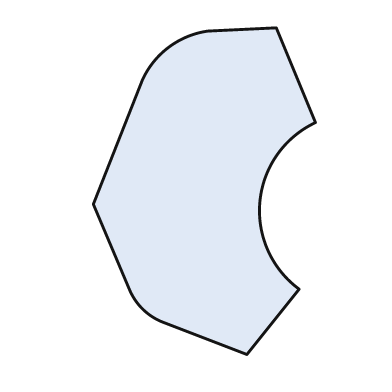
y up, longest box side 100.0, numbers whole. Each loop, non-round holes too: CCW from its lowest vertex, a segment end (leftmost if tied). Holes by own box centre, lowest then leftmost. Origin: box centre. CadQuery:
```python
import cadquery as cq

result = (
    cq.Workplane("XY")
    .moveTo(13.0, -50.0)
    .lineTo(29.0, -30.0)
    .threePointArc((17.0, -3.0), (34.0, 21.0))
    .lineTo(22.0, 50.0)
    .lineTo(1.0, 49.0)
    .threePointArc((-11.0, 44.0), (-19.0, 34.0))
    .lineTo(-34.0, -4.0)
    .lineTo(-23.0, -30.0)
    .threePointArc((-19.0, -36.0), (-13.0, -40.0))
    .close()
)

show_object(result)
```